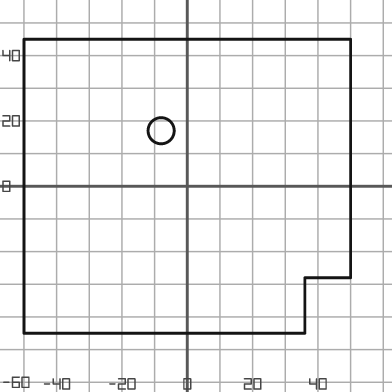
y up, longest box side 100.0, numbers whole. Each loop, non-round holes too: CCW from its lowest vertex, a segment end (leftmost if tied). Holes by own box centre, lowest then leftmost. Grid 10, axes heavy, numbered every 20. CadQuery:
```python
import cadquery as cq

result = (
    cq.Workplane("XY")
    .moveTo(-50.0, -45.0)
    .lineTo(36.0, -45.0)
    .lineTo(36.0, -28.0)
    .lineTo(50.0, -28.0)
    .lineTo(50.0, 45.0)
    .lineTo(-50.0, 45.0)
    .close()
    .moveTo(-8.0, 17.0)
    .circle(4.0)
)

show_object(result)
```